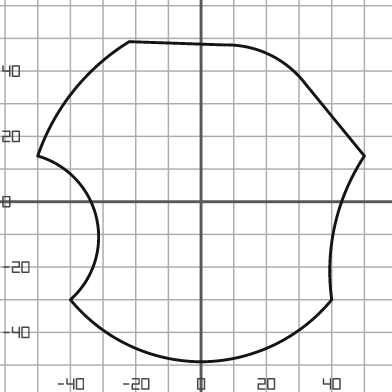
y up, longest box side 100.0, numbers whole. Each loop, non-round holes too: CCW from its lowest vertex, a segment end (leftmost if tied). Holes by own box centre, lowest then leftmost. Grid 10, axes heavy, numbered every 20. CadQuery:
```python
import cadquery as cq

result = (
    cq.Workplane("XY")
    .moveTo(0.0, -49.0)
    .threePointArc((22.0, -44.0), (40.0, -30.0))
    .threePointArc((41.0, -7.0), (50.0, 14.0))
    .lineTo(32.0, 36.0)
    .threePointArc((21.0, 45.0), (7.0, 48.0))
    .lineTo(-22.0, 49.0)
    .threePointArc((-39.0, 34.0), (-50.0, 14.0))
    .threePointArc((-32.0, -5.0), (-40.0, -30.0))
    .threePointArc((-22.0, -44.0), (0.0, -49.0))
    .close()
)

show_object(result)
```